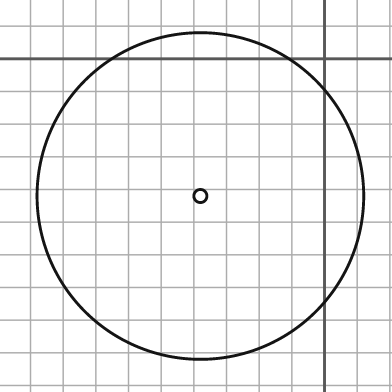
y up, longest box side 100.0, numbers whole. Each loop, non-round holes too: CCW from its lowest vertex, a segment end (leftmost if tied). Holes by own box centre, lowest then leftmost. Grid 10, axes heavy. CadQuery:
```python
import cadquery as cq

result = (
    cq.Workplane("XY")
    .moveTo(-38.0, -42.0)
    .circle(50.0)
    .moveTo(-38.0, -42.0)
    .circle(2.0)
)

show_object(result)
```